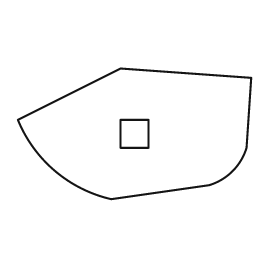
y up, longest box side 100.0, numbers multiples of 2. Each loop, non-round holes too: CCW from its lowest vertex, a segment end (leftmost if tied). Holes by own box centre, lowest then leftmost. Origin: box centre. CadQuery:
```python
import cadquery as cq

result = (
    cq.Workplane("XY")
    .moveTo(-10.0, -28.0)
    .lineTo(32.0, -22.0)
    .threePointArc((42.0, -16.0), (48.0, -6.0))
    .lineTo(50.0, 24.0)
    .lineTo(-6.0, 28.0)
    .lineTo(-50.0, 6.0)
    .threePointArc((-34.0, -16.0), (-10.0, -28.0))
    .close()
    .moveTo(-6.0, -6.0)
    .lineTo(6.0, -6.0)
    .lineTo(6.0, 6.0)
    .lineTo(-6.0, 6.0)
    .close()
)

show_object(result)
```